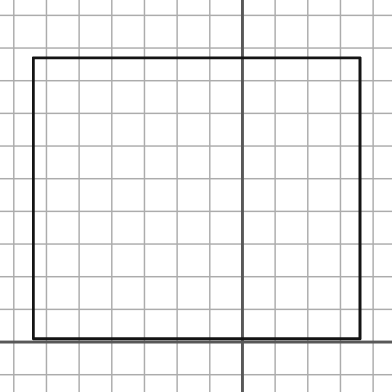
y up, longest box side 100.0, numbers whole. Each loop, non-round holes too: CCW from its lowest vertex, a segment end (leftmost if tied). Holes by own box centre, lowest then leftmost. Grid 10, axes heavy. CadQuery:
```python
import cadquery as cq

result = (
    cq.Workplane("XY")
    .moveTo(-64.0, 1.0)
    .lineTo(36.0, 1.0)
    .lineTo(36.0, 87.0)
    .lineTo(-64.0, 87.0)
    .close()
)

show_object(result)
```